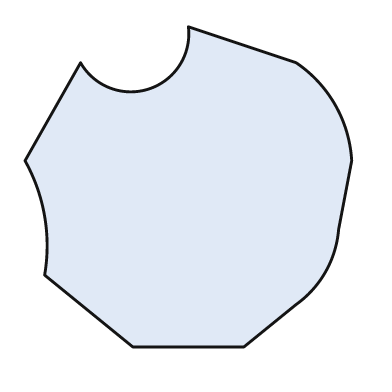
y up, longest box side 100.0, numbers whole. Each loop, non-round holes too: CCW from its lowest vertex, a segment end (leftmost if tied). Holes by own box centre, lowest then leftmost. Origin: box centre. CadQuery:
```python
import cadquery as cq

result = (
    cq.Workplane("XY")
    .moveTo(-17.0, -49.0)
    .lineTo(17.0, -49.0)
    .lineTo(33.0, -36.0)
    .threePointArc((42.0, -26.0), (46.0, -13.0))
    .lineTo(50.0, 8.0)
    .threePointArc((45.0, 25.0), (33.0, 38.0))
    .lineTo(0.0, 49.0)
    .threePointArc((-12.0, 30.0), (-33.0, 38.0))
    .lineTo(-50.0, 8.0)
    .threePointArc((-44.0, -9.0), (-44.0, -27.0))
    .close()
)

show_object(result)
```